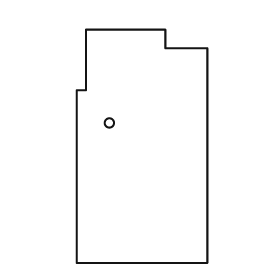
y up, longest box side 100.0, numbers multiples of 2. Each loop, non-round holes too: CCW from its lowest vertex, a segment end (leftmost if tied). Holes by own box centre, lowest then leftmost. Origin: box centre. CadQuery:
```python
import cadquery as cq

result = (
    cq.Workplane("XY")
    .moveTo(-28.0, -50.0)
    .lineTo(28.0, -50.0)
    .lineTo(28.0, 42.0)
    .lineTo(10.0, 42.0)
    .lineTo(10.0, 50.0)
    .lineTo(-24.0, 50.0)
    .lineTo(-24.0, 24.0)
    .lineTo(-28.0, 24.0)
    .close()
    .moveTo(-14.0, 10.0)
    .circle(2.0)
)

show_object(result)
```